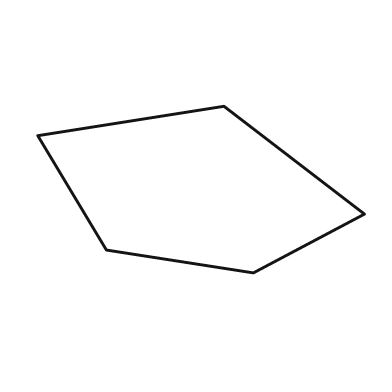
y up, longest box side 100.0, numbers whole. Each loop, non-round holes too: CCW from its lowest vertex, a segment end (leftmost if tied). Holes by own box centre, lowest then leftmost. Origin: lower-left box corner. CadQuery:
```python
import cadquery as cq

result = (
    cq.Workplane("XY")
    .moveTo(66.0, 0.0)
    .lineTo(100.0, 18.0)
    .lineTo(57.0, 51.0)
    .lineTo(0.0, 42.0)
    .lineTo(21.0, 7.0)
    .close()
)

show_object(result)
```